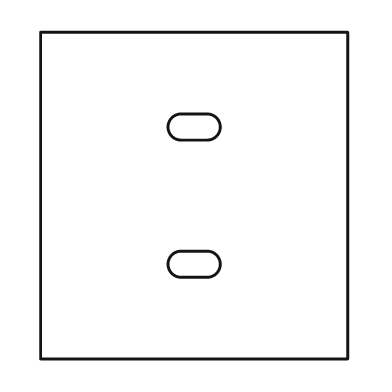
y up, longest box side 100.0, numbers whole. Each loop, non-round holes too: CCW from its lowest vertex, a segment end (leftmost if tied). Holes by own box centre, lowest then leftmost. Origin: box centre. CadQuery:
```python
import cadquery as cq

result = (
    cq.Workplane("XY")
    .moveTo(-47.0, -50.0)
    .lineTo(47.0, -50.0)
    .lineTo(47.0, 50.0)
    .lineTo(-47.0, 50.0)
    .close()
    .moveTo(-4.0, -25.0)
    .lineTo(4.0, -25.0)
    .threePointArc((8.0, -21.0), (4.0, -17.0))
    .lineTo(-4.0, -17.0)
    .threePointArc((-8.0, -21.0), (-4.0, -25.0))
    .close()
    .moveTo(-4.0, 17.0)
    .lineTo(4.0, 17.0)
    .threePointArc((8.0, 21.0), (4.0, 25.0))
    .lineTo(-4.0, 25.0)
    .threePointArc((-8.0, 21.0), (-4.0, 17.0))
    .close()
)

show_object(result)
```